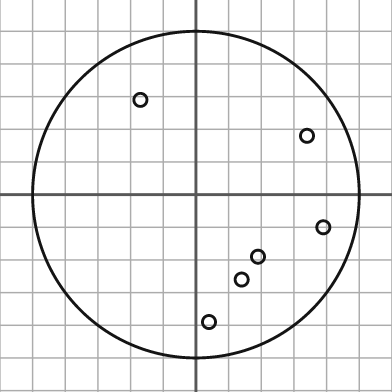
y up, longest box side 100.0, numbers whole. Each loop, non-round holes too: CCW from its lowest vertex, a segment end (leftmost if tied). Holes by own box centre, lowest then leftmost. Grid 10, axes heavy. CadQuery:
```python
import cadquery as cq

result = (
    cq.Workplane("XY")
    .moveTo(0.0, 0.0)
    .circle(50.0)
    .moveTo(4.0, -39.0)
    .circle(2.0)
    .moveTo(14.0, -26.0)
    .circle(2.0)
    .moveTo(19.0, -19.0)
    .circle(2.0)
    .moveTo(39.0, -10.0)
    .circle(2.0)
    .moveTo(34.0, 18.0)
    .circle(2.0)
    .moveTo(-17.0, 29.0)
    .circle(2.0)
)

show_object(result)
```